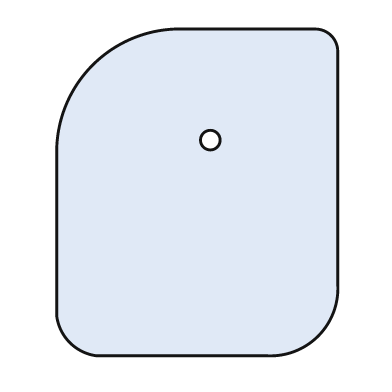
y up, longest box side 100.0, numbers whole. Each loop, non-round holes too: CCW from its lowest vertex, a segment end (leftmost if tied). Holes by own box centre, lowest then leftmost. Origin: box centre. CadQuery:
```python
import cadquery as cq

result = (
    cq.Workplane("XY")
    .moveTo(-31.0, -50.0)
    .lineTo(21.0, -50.0)
    .threePointArc((37.0, -44.0), (43.0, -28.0))
    .lineTo(43.0, 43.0)
    .threePointArc((41.0, 48.0), (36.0, 50.0))
    .lineTo(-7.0, 50.0)
    .threePointArc((-32.0, 39.0), (-43.0, 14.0))
    .lineTo(-43.0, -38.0)
    .threePointArc((-39.0, -46.0), (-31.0, -50.0))
    .close()
    .moveTo(4.0, 16.0)
    .circle(3.0)
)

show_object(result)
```